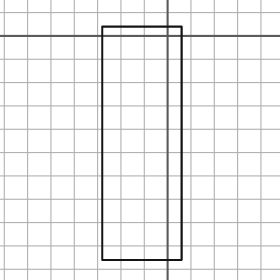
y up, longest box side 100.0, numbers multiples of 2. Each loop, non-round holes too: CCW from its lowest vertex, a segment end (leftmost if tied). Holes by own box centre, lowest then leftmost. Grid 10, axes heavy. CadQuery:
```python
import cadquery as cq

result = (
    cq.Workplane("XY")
    .moveTo(-28.0, -96.0)
    .lineTo(6.0, -96.0)
    .lineTo(6.0, 4.0)
    .lineTo(-28.0, 4.0)
    .close()
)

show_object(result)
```